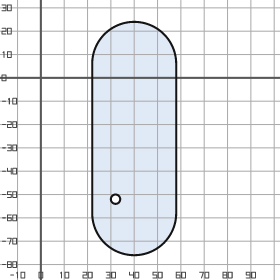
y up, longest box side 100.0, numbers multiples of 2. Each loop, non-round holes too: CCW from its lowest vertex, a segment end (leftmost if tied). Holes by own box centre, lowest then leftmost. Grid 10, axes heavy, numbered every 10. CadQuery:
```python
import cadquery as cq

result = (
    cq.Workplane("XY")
    .moveTo(22.0, -58.0)
    .threePointArc((40.0, -76.0), (58.0, -58.0))
    .lineTo(58.0, 6.0)
    .threePointArc((40.0, 24.0), (22.0, 6.0))
    .close()
    .moveTo(32.0, -52.0)
    .circle(2.0)
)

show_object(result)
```